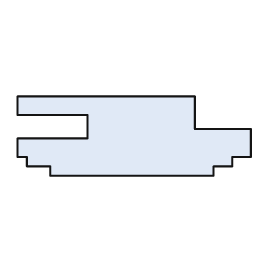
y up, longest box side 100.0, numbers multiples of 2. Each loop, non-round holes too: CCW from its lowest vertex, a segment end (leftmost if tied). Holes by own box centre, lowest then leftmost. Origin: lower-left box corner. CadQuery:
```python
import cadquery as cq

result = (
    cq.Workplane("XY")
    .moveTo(14.0, 0.0)
    .lineTo(84.0, 0.0)
    .lineTo(84.0, 4.0)
    .lineTo(92.0, 4.0)
    .lineTo(92.0, 8.0)
    .lineTo(100.0, 8.0)
    .lineTo(100.0, 20.0)
    .lineTo(76.0, 20.0)
    .lineTo(76.0, 34.0)
    .lineTo(0.0, 34.0)
    .lineTo(0.0, 26.0)
    .lineTo(30.0, 26.0)
    .lineTo(30.0, 16.0)
    .lineTo(0.0, 16.0)
    .lineTo(0.0, 8.0)
    .lineTo(4.0, 8.0)
    .lineTo(4.0, 4.0)
    .lineTo(14.0, 4.0)
    .close()
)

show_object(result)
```